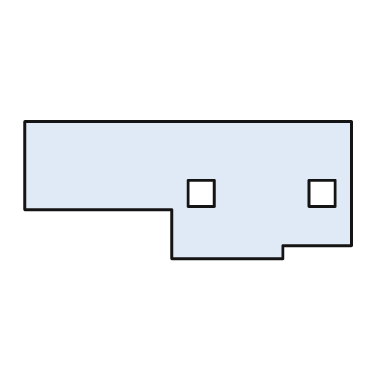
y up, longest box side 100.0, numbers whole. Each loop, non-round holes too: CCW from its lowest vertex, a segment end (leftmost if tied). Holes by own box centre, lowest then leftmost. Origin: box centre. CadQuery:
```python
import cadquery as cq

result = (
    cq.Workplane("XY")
    .moveTo(-5.0, -21.0)
    .lineTo(29.0, -21.0)
    .lineTo(29.0, -17.0)
    .lineTo(50.0, -17.0)
    .lineTo(50.0, 21.0)
    .lineTo(-50.0, 21.0)
    .lineTo(-50.0, -6.0)
    .lineTo(-5.0, -6.0)
    .close()
    .moveTo(0.0, -5.0)
    .lineTo(8.0, -5.0)
    .lineTo(8.0, 3.0)
    .lineTo(0.0, 3.0)
    .close()
    .moveTo(37.0, -5.0)
    .lineTo(45.0, -5.0)
    .lineTo(45.0, 3.0)
    .lineTo(37.0, 3.0)
    .close()
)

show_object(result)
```